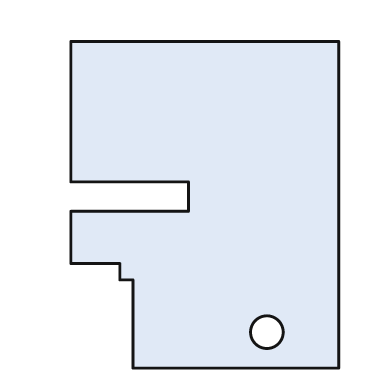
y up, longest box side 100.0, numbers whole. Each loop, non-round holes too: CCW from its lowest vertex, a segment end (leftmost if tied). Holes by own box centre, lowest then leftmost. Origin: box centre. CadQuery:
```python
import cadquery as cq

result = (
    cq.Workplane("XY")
    .moveTo(-22.0, -50.0)
    .lineTo(41.0, -50.0)
    .lineTo(41.0, 50.0)
    .lineTo(-41.0, 50.0)
    .lineTo(-41.0, 7.0)
    .lineTo(-5.0, 7.0)
    .lineTo(-5.0, -2.0)
    .lineTo(-41.0, -2.0)
    .lineTo(-41.0, -18.0)
    .lineTo(-26.0, -18.0)
    .lineTo(-26.0, -23.0)
    .lineTo(-22.0, -23.0)
    .close()
    .moveTo(19.0, -39.0)
    .circle(5.0)
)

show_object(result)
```